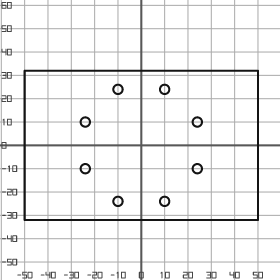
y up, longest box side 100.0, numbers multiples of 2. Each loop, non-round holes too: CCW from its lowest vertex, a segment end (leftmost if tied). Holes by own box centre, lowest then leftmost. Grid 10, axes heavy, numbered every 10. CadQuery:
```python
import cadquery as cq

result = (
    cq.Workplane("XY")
    .moveTo(-50.0, -32.0)
    .lineTo(50.0, -32.0)
    .lineTo(50.0, 32.0)
    .lineTo(-50.0, 32.0)
    .close()
    .moveTo(-10.0, -24.0)
    .circle(2.0)
    .moveTo(10.0, -24.0)
    .circle(2.0)
    .moveTo(-24.0, -10.0)
    .circle(2.0)
    .moveTo(24.0, -10.0)
    .circle(2.0)
    .moveTo(-24.0, 10.0)
    .circle(2.0)
    .moveTo(24.0, 10.0)
    .circle(2.0)
    .moveTo(-10.0, 24.0)
    .circle(2.0)
    .moveTo(10.0, 24.0)
    .circle(2.0)
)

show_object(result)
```